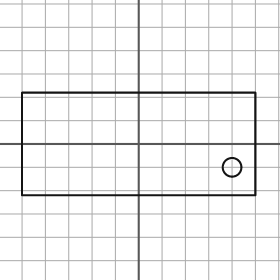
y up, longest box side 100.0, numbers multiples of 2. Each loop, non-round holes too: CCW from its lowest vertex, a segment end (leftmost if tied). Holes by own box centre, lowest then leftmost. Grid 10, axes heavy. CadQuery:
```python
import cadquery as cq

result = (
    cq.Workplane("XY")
    .moveTo(-50.0, -22.0)
    .lineTo(50.0, -22.0)
    .lineTo(50.0, 22.0)
    .lineTo(-50.0, 22.0)
    .close()
    .moveTo(40.0, -10.0)
    .circle(4.0)
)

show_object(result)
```